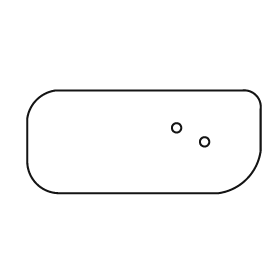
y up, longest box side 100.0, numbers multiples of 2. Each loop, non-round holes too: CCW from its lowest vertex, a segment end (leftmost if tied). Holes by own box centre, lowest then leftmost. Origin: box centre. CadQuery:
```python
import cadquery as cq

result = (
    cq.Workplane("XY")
    .moveTo(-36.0, -22.0)
    .lineTo(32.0, -22.0)
    .threePointArc((44.0, -16.0), (50.0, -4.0))
    .lineTo(50.0, 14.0)
    .threePointArc((48.0, 20.0), (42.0, 22.0))
    .lineTo(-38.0, 22.0)
    .threePointArc((-46.0, 18.0), (-50.0, 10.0))
    .lineTo(-50.0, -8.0)
    .threePointArc((-46.0, -18.0), (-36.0, -22.0))
    .close()
    .moveTo(26.0, 0.0)
    .circle(2.0)
    .moveTo(14.0, 6.0)
    .circle(2.0)
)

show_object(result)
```